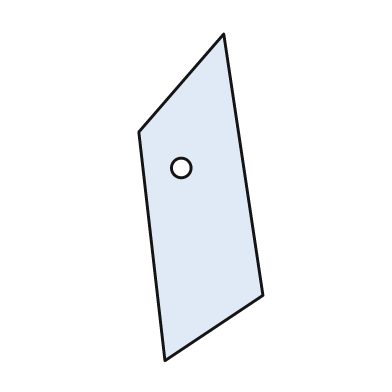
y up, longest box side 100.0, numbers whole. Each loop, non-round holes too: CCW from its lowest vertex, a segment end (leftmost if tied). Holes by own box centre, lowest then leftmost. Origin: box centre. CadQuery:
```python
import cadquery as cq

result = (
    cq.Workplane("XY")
    .moveTo(-11.0, -50.0)
    .lineTo(19.0, -30.0)
    .lineTo(7.0, 50.0)
    .lineTo(-19.0, 20.0)
    .close()
    .moveTo(-6.0, 9.0)
    .circle(3.0)
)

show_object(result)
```